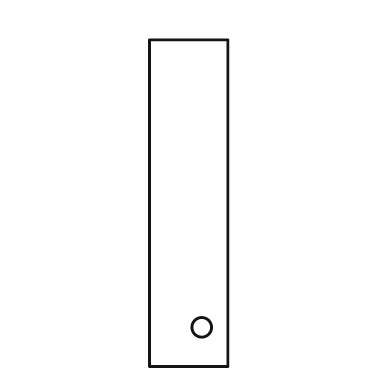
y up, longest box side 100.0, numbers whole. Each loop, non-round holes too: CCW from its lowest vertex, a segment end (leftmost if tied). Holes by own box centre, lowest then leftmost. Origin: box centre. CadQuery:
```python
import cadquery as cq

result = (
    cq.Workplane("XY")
    .moveTo(-12.0, -50.0)
    .lineTo(12.0, -50.0)
    .lineTo(12.0, 50.0)
    .lineTo(-12.0, 50.0)
    .close()
    .moveTo(4.0, -38.0)
    .circle(3.0)
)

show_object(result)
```